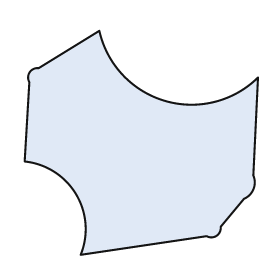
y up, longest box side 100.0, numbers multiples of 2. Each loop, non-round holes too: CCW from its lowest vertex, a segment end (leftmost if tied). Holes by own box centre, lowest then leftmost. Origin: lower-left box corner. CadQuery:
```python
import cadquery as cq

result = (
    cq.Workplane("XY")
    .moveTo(24.0, 0.0)
    .lineTo(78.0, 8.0)
    .threePointArc((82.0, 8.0), (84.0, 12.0))
    .lineTo(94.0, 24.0)
    .threePointArc((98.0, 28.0), (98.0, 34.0))
    .lineTo(100.0, 76.0)
    .threePointArc((60.0, 66.0), (32.0, 96.0))
    .lineTo(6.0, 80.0)
    .threePointArc((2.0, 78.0), (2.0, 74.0))
    .lineTo(0.0, 40.0)
    .threePointArc((22.0, 26.0), (24.0, 0.0))
    .close()
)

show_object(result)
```